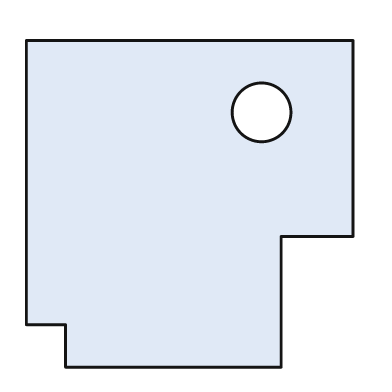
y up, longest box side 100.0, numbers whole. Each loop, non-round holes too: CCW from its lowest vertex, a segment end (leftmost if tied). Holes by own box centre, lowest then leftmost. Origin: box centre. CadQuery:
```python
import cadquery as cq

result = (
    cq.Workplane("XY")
    .moveTo(-38.0, -50.0)
    .lineTo(28.0, -50.0)
    .lineTo(28.0, -10.0)
    .lineTo(50.0, -10.0)
    .lineTo(50.0, 50.0)
    .lineTo(-50.0, 50.0)
    .lineTo(-50.0, -37.0)
    .lineTo(-38.0, -37.0)
    .close()
    .moveTo(22.0, 28.0)
    .circle(9.0)
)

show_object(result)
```